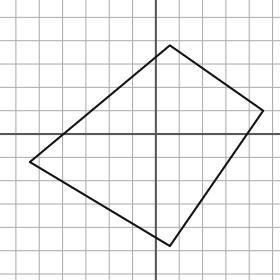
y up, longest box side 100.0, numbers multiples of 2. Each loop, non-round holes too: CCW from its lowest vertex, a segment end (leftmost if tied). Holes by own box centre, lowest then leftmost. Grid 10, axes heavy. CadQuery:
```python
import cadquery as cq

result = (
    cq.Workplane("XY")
    .moveTo(6.0, -48.0)
    .lineTo(46.0, 10.0)
    .lineTo(6.0, 38.0)
    .lineTo(-54.0, -12.0)
    .close()
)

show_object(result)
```